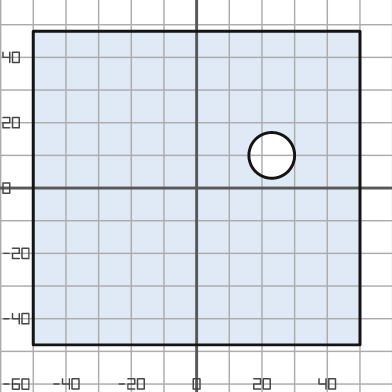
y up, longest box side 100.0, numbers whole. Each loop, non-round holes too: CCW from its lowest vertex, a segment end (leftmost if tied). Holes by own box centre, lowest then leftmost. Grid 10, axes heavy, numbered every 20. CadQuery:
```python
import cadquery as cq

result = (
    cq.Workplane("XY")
    .moveTo(-50.0, -48.0)
    .lineTo(50.0, -48.0)
    .lineTo(50.0, 48.0)
    .lineTo(-50.0, 48.0)
    .close()
    .moveTo(23.0, 10.0)
    .circle(7.0)
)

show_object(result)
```